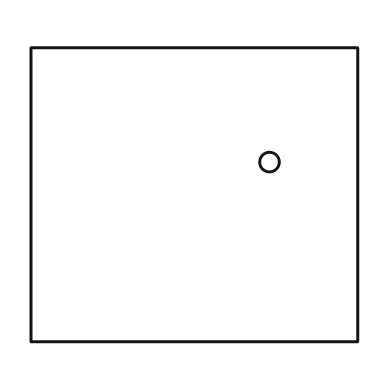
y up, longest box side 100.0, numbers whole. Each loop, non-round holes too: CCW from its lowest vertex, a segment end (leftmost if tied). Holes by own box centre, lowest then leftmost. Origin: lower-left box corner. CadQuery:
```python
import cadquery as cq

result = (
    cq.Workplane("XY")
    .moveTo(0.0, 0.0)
    .lineTo(100.0, 0.0)
    .lineTo(100.0, 90.0)
    .lineTo(0.0, 90.0)
    .close()
    .moveTo(73.0, 55.0)
    .circle(3.0)
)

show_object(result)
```